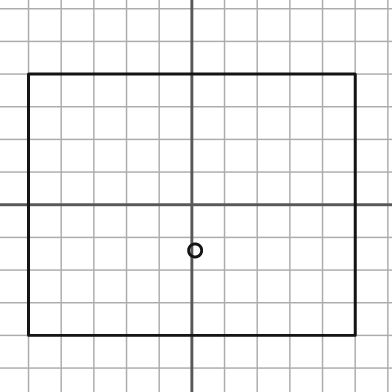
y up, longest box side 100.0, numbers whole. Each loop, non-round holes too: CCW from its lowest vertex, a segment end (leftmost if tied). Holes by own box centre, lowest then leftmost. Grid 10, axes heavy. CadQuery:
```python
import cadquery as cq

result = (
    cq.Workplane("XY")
    .moveTo(-50.0, -40.0)
    .lineTo(50.0, -40.0)
    .lineTo(50.0, 40.0)
    .lineTo(-50.0, 40.0)
    .close()
    .moveTo(1.0, -14.0)
    .circle(2.0)
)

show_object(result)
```